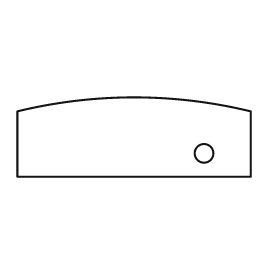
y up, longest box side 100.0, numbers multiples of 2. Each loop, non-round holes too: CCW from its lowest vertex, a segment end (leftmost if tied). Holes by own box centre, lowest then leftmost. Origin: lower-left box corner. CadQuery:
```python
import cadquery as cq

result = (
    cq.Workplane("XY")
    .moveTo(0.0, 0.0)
    .lineTo(100.0, 0.0)
    .lineTo(100.0, 28.0)
    .threePointArc((50.0, 34.0), (0.0, 28.0))
    .close()
    .moveTo(80.0, 10.0)
    .circle(4.0)
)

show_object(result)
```